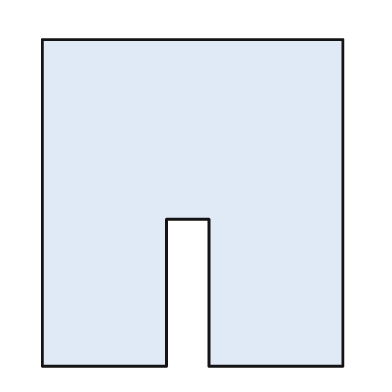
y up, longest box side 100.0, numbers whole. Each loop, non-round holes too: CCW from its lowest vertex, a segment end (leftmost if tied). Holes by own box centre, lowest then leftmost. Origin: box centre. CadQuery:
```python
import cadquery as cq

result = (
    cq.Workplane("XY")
    .moveTo(-46.0, -50.0)
    .lineTo(-8.0, -50.0)
    .lineTo(-8.0, -5.0)
    .lineTo(5.0, -5.0)
    .lineTo(5.0, -50.0)
    .lineTo(46.0, -50.0)
    .lineTo(46.0, 50.0)
    .lineTo(-46.0, 50.0)
    .close()
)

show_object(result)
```